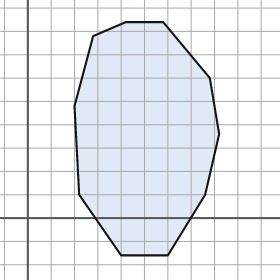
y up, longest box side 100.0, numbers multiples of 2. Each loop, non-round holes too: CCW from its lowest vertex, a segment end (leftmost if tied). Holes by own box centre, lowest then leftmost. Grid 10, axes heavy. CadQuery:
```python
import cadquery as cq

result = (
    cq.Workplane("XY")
    .moveTo(40.0, -16.0)
    .lineTo(60.0, -16.0)
    .lineTo(76.0, 10.0)
    .lineTo(82.0, 36.0)
    .lineTo(78.0, 60.0)
    .lineTo(58.0, 84.0)
    .lineTo(42.0, 84.0)
    .lineTo(28.0, 78.0)
    .lineTo(20.0, 48.0)
    .lineTo(22.0, 10.0)
    .close()
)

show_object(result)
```